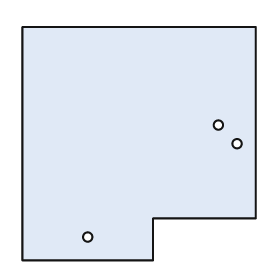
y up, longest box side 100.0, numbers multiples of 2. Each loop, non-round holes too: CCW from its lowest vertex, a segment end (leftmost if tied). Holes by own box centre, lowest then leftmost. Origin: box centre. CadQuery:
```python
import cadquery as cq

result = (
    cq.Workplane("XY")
    .moveTo(-50.0, -50.0)
    .lineTo(6.0, -50.0)
    .lineTo(6.0, -32.0)
    .lineTo(50.0, -32.0)
    .lineTo(50.0, 50.0)
    .lineTo(-50.0, 50.0)
    .close()
    .moveTo(-22.0, -40.0)
    .circle(2.0)
    .moveTo(42.0, 0.0)
    .circle(2.0)
    .moveTo(34.0, 8.0)
    .circle(2.0)
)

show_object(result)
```